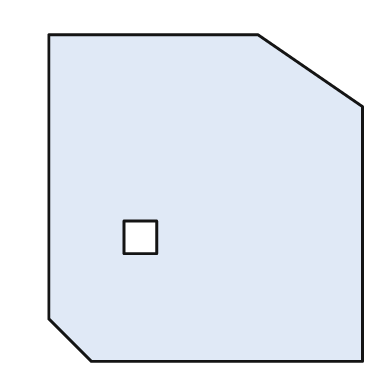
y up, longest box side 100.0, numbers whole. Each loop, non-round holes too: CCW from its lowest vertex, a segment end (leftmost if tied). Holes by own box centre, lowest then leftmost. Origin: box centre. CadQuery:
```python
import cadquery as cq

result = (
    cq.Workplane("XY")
    .moveTo(-35.0, -50.0)
    .lineTo(48.0, -50.0)
    .lineTo(48.0, 28.0)
    .lineTo(16.0, 50.0)
    .lineTo(-48.0, 50.0)
    .lineTo(-48.0, -37.0)
    .close()
    .moveTo(-25.0, -17.0)
    .lineTo(-15.0, -17.0)
    .lineTo(-15.0, -7.0)
    .lineTo(-25.0, -7.0)
    .close()
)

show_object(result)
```